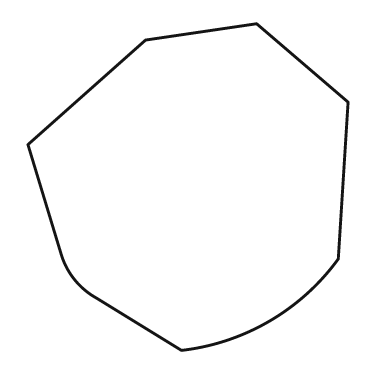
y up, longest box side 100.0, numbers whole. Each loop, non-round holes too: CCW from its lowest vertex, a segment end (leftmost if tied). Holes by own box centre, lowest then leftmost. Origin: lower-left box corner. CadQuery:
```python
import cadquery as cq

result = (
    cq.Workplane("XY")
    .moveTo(47.0, 0.0)
    .threePointArc((74.0, 9.0), (95.0, 28.0))
    .lineTo(98.0, 76.0)
    .lineTo(70.0, 100.0)
    .lineTo(36.0, 95.0)
    .lineTo(0.0, 63.0)
    .lineTo(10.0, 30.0)
    .threePointArc((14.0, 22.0), (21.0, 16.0))
    .close()
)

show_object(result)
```